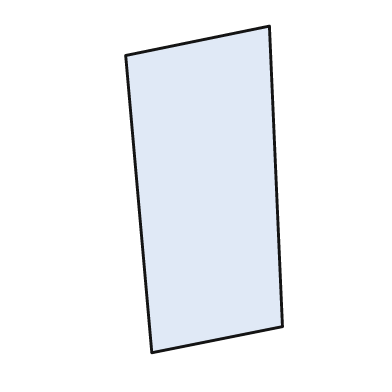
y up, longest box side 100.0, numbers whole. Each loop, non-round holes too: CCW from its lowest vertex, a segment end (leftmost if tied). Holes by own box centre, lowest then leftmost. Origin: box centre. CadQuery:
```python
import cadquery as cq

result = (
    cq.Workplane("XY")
    .moveTo(-16.0, -50.0)
    .lineTo(24.0, -42.0)
    .lineTo(20.0, 50.0)
    .lineTo(-24.0, 41.0)
    .close()
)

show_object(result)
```